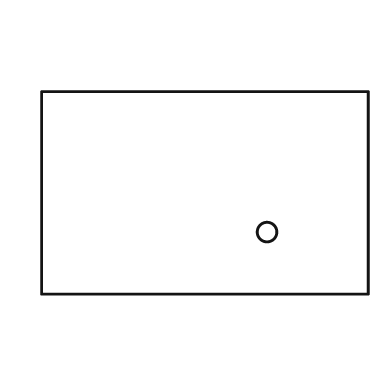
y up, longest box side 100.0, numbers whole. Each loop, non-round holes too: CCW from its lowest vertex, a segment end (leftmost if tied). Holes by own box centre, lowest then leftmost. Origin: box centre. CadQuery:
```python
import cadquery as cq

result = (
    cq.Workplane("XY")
    .moveTo(-50.0, -31.0)
    .lineTo(50.0, -31.0)
    .lineTo(50.0, 31.0)
    .lineTo(-50.0, 31.0)
    .close()
    .moveTo(19.0, -12.0)
    .circle(3.0)
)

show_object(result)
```